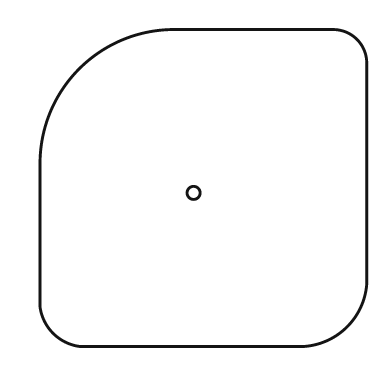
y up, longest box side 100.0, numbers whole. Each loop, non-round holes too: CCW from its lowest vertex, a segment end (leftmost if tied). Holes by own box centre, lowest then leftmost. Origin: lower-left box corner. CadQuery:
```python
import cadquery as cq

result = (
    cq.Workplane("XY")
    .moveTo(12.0, 0.0)
    .lineTo(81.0, 0.0)
    .threePointArc((94.0, 6.0), (100.0, 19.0))
    .lineTo(100.0, 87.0)
    .threePointArc((97.0, 94.0), (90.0, 97.0))
    .lineTo(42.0, 97.0)
    .threePointArc((12.0, 85.0), (0.0, 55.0))
    .lineTo(0.0, 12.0)
    .threePointArc((4.0, 4.0), (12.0, 0.0))
    .close()
    .moveTo(47.0, 47.0)
    .circle(2.0)
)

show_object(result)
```